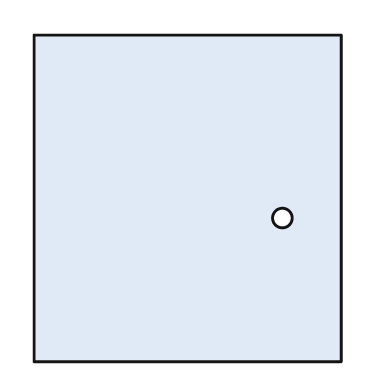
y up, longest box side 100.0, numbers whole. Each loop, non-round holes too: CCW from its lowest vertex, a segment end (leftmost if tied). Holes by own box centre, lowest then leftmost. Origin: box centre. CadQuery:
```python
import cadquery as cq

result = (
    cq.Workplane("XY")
    .moveTo(-47.0, -50.0)
    .lineTo(47.0, -50.0)
    .lineTo(47.0, 50.0)
    .lineTo(-47.0, 50.0)
    .close()
    .moveTo(29.0, -6.0)
    .circle(3.0)
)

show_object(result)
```